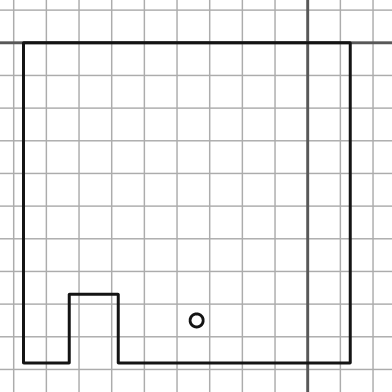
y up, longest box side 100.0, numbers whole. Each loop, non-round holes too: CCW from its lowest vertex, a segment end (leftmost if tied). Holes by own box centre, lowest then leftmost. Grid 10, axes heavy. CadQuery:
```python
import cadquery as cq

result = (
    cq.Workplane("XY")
    .moveTo(-87.0, -98.0)
    .lineTo(-73.0, -98.0)
    .lineTo(-73.0, -77.0)
    .lineTo(-58.0, -77.0)
    .lineTo(-58.0, -98.0)
    .lineTo(13.0, -98.0)
    .lineTo(13.0, 0.0)
    .lineTo(-87.0, 0.0)
    .close()
    .moveTo(-34.0, -85.0)
    .circle(2.0)
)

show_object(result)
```